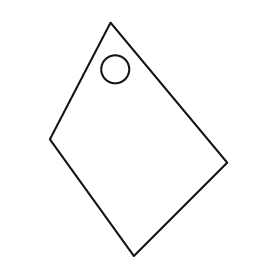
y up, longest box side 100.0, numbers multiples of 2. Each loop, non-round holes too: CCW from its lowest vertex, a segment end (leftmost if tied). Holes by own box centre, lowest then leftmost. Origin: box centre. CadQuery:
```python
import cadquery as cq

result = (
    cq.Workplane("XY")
    .moveTo(-2.0, -50.0)
    .lineTo(38.0, -10.0)
    .lineTo(-12.0, 50.0)
    .lineTo(-38.0, 0.0)
    .close()
    .moveTo(-10.0, 30.0)
    .circle(6.0)
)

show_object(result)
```